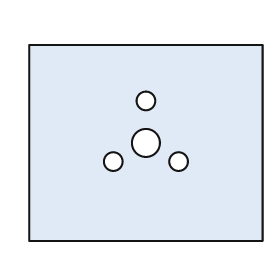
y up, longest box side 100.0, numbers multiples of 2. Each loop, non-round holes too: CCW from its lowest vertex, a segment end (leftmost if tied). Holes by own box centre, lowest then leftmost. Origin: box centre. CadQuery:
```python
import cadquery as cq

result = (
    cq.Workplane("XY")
    .moveTo(-50.0, -42.0)
    .lineTo(50.0, -42.0)
    .lineTo(50.0, 42.0)
    .lineTo(-50.0, 42.0)
    .close()
    .moveTo(-14.0, -8.0)
    .circle(4.0)
    .moveTo(14.0, -8.0)
    .circle(4.0)
    .moveTo(0.0, 0.0)
    .circle(6.0)
    .moveTo(0.0, 18.0)
    .circle(4.0)
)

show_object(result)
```